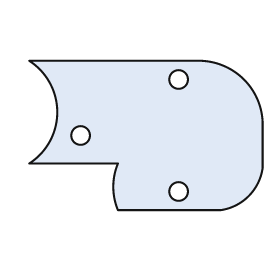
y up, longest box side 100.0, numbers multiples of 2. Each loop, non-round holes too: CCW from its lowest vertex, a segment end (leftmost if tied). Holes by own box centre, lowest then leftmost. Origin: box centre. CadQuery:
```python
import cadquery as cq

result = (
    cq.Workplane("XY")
    .moveTo(-12.0, -32.0)
    .lineTo(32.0, -32.0)
    .threePointArc((44.0, -26.0), (50.0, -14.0))
    .lineTo(50.0, 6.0)
    .threePointArc((42.0, 24.0), (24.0, 32.0))
    .lineTo(-50.0, 32.0)
    .threePointArc((-38.0, 10.0), (-50.0, -12.0))
    .lineTo(-12.0, -12.0)
    .threePointArc((-14.0, -22.0), (-12.0, -32.0))
    .close()
    .moveTo(14.0, -24.0)
    .circle(4.0)
    .moveTo(-28.0, 0.0)
    .circle(4.0)
    .moveTo(14.0, 24.0)
    .circle(4.0)
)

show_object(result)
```